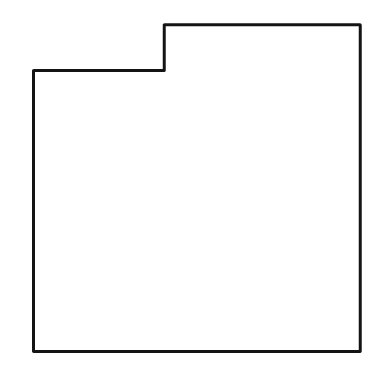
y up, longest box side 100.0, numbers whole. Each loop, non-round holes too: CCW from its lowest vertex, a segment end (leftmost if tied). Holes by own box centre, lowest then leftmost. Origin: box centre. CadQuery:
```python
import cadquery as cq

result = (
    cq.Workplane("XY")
    .moveTo(-50.0, -50.0)
    .lineTo(50.0, -50.0)
    .lineTo(50.0, 50.0)
    .lineTo(-10.0, 50.0)
    .lineTo(-10.0, 36.0)
    .lineTo(-50.0, 36.0)
    .close()
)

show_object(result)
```